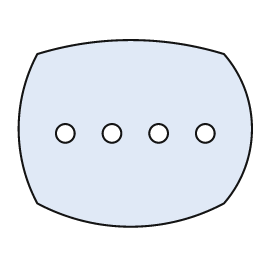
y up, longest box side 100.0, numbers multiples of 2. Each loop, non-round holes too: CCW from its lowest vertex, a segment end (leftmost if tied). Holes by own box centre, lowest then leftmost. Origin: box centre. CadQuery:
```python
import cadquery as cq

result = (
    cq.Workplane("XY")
    .moveTo(-42.0, -30.0)
    .threePointArc((-2.0, -40.0), (38.0, -30.0))
    .threePointArc((50.0, 2.0), (38.0, 34.0))
    .threePointArc((-2.0, 40.0), (-42.0, 34.0))
    .threePointArc((-50.0, 2.0), (-42.0, -30.0))
    .close()
    .moveTo(-30.0, 0.0)
    .circle(4.0)
    .moveTo(-10.0, 0.0)
    .circle(4.0)
    .moveTo(10.0, 0.0)
    .circle(4.0)
    .moveTo(30.0, 0.0)
    .circle(4.0)
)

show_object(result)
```